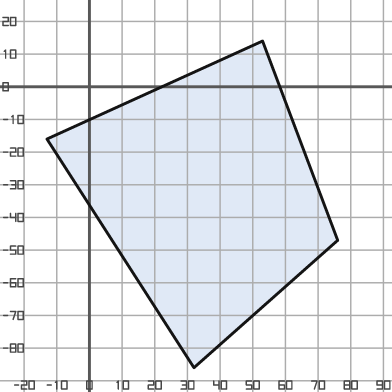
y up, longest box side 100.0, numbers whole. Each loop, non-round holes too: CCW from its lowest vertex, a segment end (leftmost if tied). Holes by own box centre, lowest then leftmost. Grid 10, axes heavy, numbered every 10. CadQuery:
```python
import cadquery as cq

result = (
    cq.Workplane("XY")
    .moveTo(32.0, -86.0)
    .lineTo(76.0, -47.0)
    .lineTo(53.0, 14.0)
    .lineTo(-13.0, -16.0)
    .close()
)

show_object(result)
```